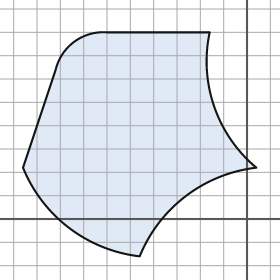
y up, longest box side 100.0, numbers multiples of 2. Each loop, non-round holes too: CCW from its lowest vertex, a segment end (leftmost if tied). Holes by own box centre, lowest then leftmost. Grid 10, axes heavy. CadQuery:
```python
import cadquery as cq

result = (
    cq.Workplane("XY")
    .moveTo(-46.0, -16.0)
    .threePointArc((-26.0, 10.0), (4.0, 22.0))
    .threePointArc((-14.0, 48.0), (-16.0, 80.0))
    .lineTo(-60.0, 80.0)
    .threePointArc((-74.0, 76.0), (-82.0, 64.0))
    .lineTo(-96.0, 22.0)
    .threePointArc((-76.0, -4.0), (-46.0, -16.0))
    .close()
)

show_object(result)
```